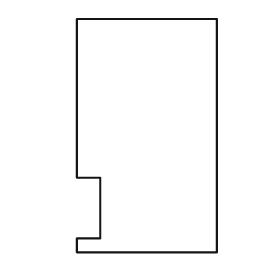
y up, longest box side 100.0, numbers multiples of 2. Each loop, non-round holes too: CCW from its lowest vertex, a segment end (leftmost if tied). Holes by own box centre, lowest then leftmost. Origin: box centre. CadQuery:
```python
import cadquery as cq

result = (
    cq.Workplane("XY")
    .moveTo(-30.0, -50.0)
    .lineTo(30.0, -50.0)
    .lineTo(30.0, 50.0)
    .lineTo(-30.0, 50.0)
    .lineTo(-30.0, -18.0)
    .lineTo(-20.0, -18.0)
    .lineTo(-20.0, -44.0)
    .lineTo(-30.0, -44.0)
    .close()
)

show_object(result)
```